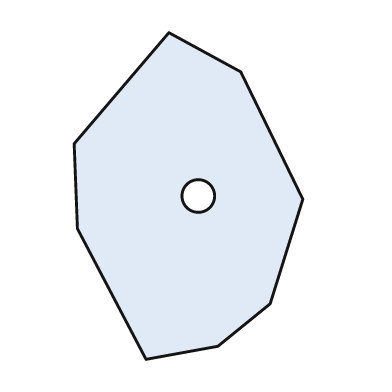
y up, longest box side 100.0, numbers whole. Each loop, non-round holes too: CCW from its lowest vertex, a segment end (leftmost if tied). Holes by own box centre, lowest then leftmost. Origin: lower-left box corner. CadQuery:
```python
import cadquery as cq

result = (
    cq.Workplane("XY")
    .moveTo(22.0, 0.0)
    .lineTo(44.0, 4.0)
    .lineTo(60.0, 17.0)
    .lineTo(70.0, 49.0)
    .lineTo(51.0, 88.0)
    .lineTo(29.0, 100.0)
    .lineTo(0.0, 66.0)
    .lineTo(1.0, 40.0)
    .close()
    .moveTo(38.0, 50.0)
    .circle(5.0)
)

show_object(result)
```